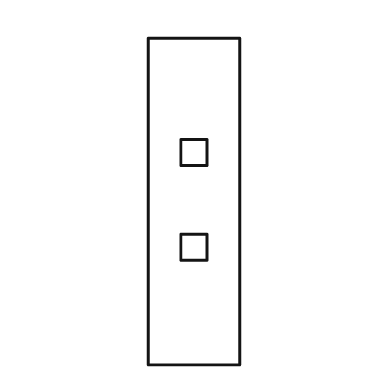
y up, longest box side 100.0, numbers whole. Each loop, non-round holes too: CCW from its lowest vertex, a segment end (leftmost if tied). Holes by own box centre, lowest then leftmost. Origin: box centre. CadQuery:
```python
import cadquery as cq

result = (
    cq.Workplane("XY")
    .moveTo(-14.0, -50.0)
    .lineTo(14.0, -50.0)
    .lineTo(14.0, 50.0)
    .lineTo(-14.0, 50.0)
    .close()
    .moveTo(-4.0, -18.0)
    .lineTo(4.0, -18.0)
    .lineTo(4.0, -10.0)
    .lineTo(-4.0, -10.0)
    .close()
    .moveTo(-4.0, 11.0)
    .lineTo(4.0, 11.0)
    .lineTo(4.0, 19.0)
    .lineTo(-4.0, 19.0)
    .close()
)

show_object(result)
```